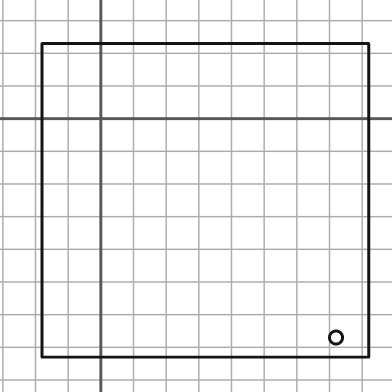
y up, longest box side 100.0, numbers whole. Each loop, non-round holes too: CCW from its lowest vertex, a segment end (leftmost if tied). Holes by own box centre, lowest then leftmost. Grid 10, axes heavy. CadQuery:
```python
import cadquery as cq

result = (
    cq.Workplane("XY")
    .moveTo(-18.0, -73.0)
    .lineTo(82.0, -73.0)
    .lineTo(82.0, 23.0)
    .lineTo(-18.0, 23.0)
    .close()
    .moveTo(72.0, -67.0)
    .circle(2.0)
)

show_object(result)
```